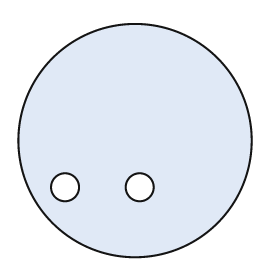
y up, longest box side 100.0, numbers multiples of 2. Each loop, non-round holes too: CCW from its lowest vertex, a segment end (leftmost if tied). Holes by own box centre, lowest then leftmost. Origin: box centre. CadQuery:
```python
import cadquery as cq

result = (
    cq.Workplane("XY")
    .moveTo(0.0, 0.0)
    .circle(50.0)
    .moveTo(-30.0, -20.0)
    .circle(6.0)
    .moveTo(2.0, -20.0)
    .circle(6.0)
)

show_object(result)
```